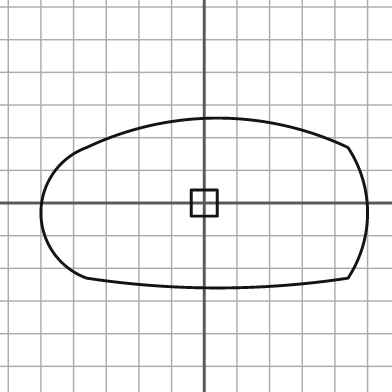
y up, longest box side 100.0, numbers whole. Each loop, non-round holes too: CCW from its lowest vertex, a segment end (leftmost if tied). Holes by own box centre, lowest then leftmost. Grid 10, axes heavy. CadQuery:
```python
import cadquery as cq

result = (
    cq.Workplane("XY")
    .moveTo(-36.0, -23.0)
    .threePointArc((4.0, -26.0), (44.0, -23.0))
    .threePointArc((50.0, -3.0), (44.0, 17.0))
    .threePointArc((4.0, 26.0), (-36.0, 17.0))
    .threePointArc((-50.0, -3.0), (-36.0, -23.0))
    .close()
    .moveTo(-4.0, -4.0)
    .lineTo(4.0, -4.0)
    .lineTo(4.0, 4.0)
    .lineTo(-4.0, 4.0)
    .close()
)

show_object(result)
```